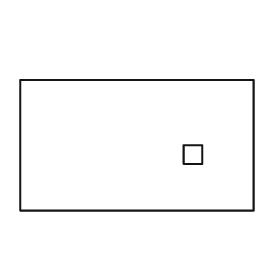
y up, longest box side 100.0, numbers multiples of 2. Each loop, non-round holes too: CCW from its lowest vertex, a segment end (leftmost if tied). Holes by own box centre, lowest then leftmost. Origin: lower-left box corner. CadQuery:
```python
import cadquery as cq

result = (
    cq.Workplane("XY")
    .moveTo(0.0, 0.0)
    .lineTo(100.0, 0.0)
    .lineTo(100.0, 56.0)
    .lineTo(0.0, 56.0)
    .close()
    .moveTo(70.0, 20.0)
    .lineTo(78.0, 20.0)
    .lineTo(78.0, 28.0)
    .lineTo(70.0, 28.0)
    .close()
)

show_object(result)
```